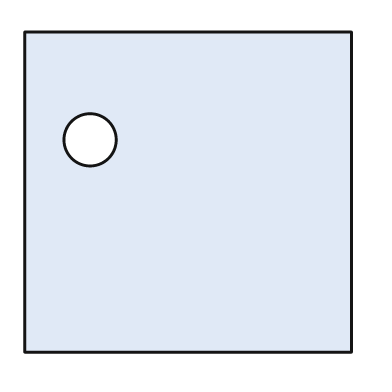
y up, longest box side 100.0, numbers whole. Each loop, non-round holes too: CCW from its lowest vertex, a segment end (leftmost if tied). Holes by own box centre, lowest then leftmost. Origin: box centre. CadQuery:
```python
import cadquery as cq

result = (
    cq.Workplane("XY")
    .moveTo(-50.0, -49.0)
    .lineTo(50.0, -49.0)
    .lineTo(50.0, 49.0)
    .lineTo(-50.0, 49.0)
    .close()
    .moveTo(-30.0, 16.0)
    .circle(8.0)
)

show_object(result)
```